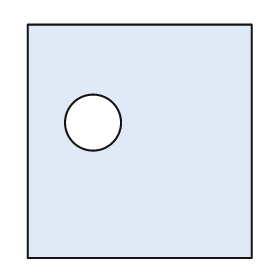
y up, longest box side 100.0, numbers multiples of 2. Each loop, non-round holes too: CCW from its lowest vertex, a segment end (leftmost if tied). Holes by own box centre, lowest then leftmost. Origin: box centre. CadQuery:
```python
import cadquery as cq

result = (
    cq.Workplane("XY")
    .moveTo(-48.0, -50.0)
    .lineTo(48.0, -50.0)
    .lineTo(48.0, 50.0)
    .lineTo(-48.0, 50.0)
    .close()
    .moveTo(-20.0, 8.0)
    .circle(12.0)
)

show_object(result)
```